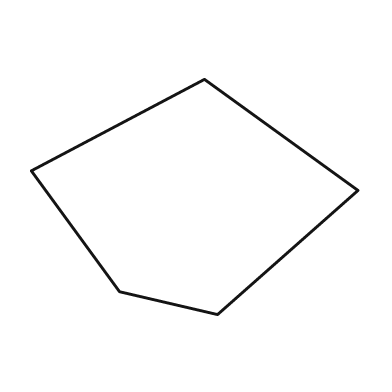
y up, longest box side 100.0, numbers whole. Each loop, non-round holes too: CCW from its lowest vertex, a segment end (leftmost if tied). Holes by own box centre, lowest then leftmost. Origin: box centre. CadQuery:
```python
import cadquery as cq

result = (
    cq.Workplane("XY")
    .moveTo(7.0, -36.0)
    .lineTo(50.0, 2.0)
    .lineTo(3.0, 36.0)
    .lineTo(-50.0, 8.0)
    .lineTo(-23.0, -29.0)
    .close()
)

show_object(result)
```